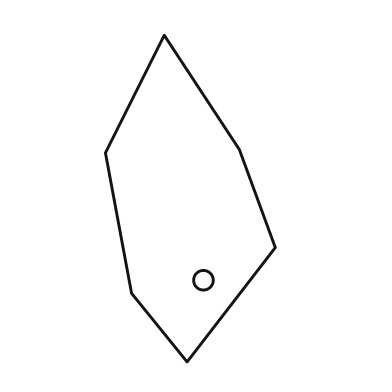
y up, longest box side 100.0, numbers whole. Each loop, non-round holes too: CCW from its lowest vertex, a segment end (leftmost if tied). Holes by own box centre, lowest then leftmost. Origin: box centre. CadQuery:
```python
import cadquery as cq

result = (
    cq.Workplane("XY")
    .moveTo(-1.0, -50.0)
    .lineTo(26.0, -15.0)
    .lineTo(15.0, 15.0)
    .lineTo(-8.0, 50.0)
    .lineTo(-26.0, 14.0)
    .lineTo(-18.0, -29.0)
    .close()
    .moveTo(4.0, -25.0)
    .circle(3.0)
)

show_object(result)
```